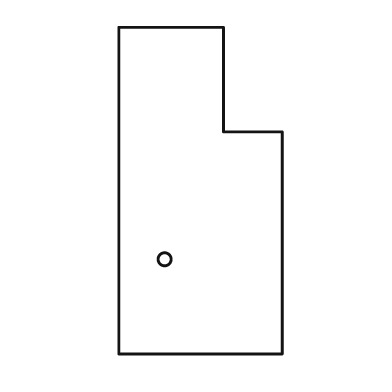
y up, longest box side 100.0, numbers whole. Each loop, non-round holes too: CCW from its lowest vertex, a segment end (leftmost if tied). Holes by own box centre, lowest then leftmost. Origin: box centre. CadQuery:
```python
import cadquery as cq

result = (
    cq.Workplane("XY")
    .moveTo(-25.0, -50.0)
    .lineTo(25.0, -50.0)
    .lineTo(25.0, 18.0)
    .lineTo(7.0, 18.0)
    .lineTo(7.0, 50.0)
    .lineTo(-25.0, 50.0)
    .close()
    .moveTo(-11.0, -21.0)
    .circle(2.0)
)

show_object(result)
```